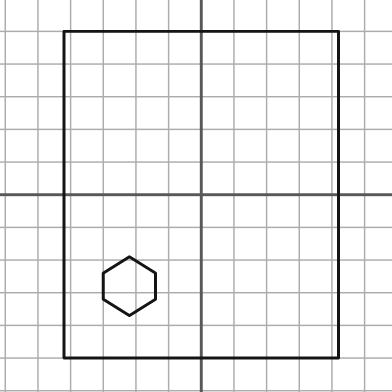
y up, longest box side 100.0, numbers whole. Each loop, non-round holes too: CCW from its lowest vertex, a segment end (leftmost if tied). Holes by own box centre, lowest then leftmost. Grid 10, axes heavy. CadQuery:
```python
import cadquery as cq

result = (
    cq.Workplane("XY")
    .moveTo(-42.0, -50.0)
    .lineTo(42.0, -50.0)
    .lineTo(42.0, 50.0)
    .lineTo(-42.0, 50.0)
    .close()
    .moveTo(-22.0, -37.0)
    .lineTo(-14.0, -32.0)
    .lineTo(-14.0, -24.0)
    .lineTo(-22.0, -19.0)
    .lineTo(-30.0, -24.0)
    .lineTo(-30.0, -32.0)
    .close()
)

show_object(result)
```